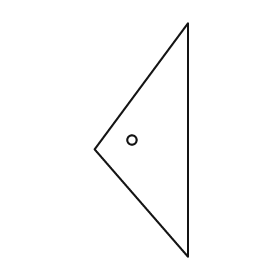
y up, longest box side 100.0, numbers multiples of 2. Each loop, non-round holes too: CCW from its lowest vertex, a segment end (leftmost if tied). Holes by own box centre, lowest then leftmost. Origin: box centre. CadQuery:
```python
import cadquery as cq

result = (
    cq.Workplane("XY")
    .moveTo(20.0, -50.0)
    .lineTo(20.0, 50.0)
    .lineTo(-20.0, -4.0)
    .close()
    .moveTo(-4.0, 0.0)
    .circle(2.0)
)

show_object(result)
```